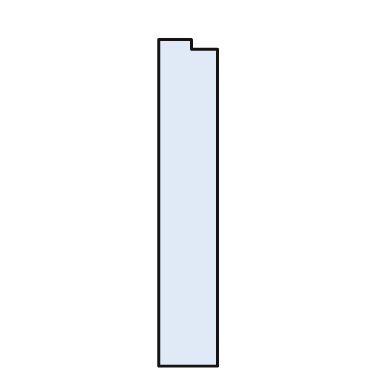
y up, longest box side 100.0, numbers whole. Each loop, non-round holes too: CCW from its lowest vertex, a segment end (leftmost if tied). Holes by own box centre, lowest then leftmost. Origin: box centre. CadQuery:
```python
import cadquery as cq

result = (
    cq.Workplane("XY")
    .moveTo(-9.0, -50.0)
    .lineTo(9.0, -50.0)
    .lineTo(9.0, 47.0)
    .lineTo(1.0, 47.0)
    .lineTo(1.0, 50.0)
    .lineTo(-9.0, 50.0)
    .close()
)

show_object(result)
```